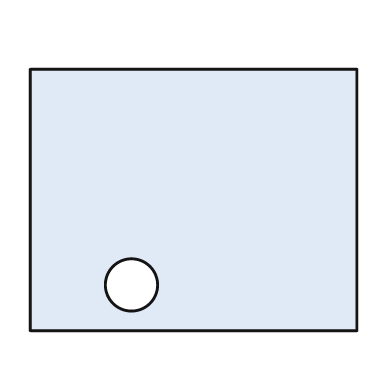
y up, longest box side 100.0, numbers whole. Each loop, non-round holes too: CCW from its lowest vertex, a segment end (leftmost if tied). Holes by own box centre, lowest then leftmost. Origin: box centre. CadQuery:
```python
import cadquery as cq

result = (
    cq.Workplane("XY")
    .moveTo(-50.0, -40.0)
    .lineTo(50.0, -40.0)
    .lineTo(50.0, 40.0)
    .lineTo(-50.0, 40.0)
    .close()
    .moveTo(-19.0, -26.0)
    .circle(8.0)
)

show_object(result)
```